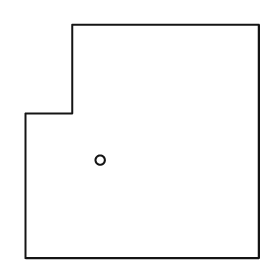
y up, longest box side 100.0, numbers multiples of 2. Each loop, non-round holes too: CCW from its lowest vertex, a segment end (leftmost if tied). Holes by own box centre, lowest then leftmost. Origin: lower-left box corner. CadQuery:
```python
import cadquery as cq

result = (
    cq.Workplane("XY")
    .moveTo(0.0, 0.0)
    .lineTo(100.0, 0.0)
    .lineTo(100.0, 100.0)
    .lineTo(20.0, 100.0)
    .lineTo(20.0, 62.0)
    .lineTo(0.0, 62.0)
    .close()
    .moveTo(32.0, 42.0)
    .circle(2.0)
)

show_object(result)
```